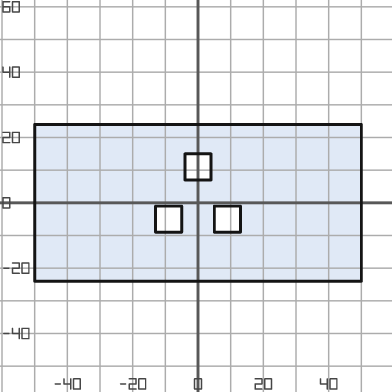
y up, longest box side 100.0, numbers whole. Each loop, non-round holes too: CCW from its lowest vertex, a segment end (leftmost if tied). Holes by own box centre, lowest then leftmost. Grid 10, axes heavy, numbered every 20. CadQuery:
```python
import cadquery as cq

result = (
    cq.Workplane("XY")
    .moveTo(-50.0, -24.0)
    .lineTo(50.0, -24.0)
    .lineTo(50.0, 24.0)
    .lineTo(-50.0, 24.0)
    .close()
    .moveTo(-13.0, -9.0)
    .lineTo(-5.0, -9.0)
    .lineTo(-5.0, -1.0)
    .lineTo(-13.0, -1.0)
    .close()
    .moveTo(5.0, -9.0)
    .lineTo(13.0, -9.0)
    .lineTo(13.0, -1.0)
    .lineTo(5.0, -1.0)
    .close()
    .moveTo(-4.0, 7.0)
    .lineTo(4.0, 7.0)
    .lineTo(4.0, 15.0)
    .lineTo(-4.0, 15.0)
    .close()
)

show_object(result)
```